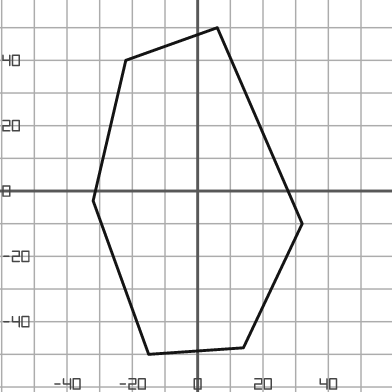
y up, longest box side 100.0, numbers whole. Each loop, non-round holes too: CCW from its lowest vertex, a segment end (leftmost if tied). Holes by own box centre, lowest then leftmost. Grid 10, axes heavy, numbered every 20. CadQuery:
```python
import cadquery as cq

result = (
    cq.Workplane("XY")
    .moveTo(-15.0, -50.0)
    .lineTo(14.0, -48.0)
    .lineTo(32.0, -10.0)
    .lineTo(6.0, 50.0)
    .lineTo(-22.0, 40.0)
    .lineTo(-32.0, -3.0)
    .close()
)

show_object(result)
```